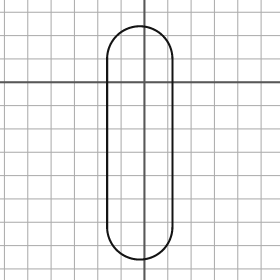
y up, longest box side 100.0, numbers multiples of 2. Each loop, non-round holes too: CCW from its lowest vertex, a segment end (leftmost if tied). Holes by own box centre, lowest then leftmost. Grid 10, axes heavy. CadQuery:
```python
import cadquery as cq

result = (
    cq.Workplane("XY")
    .moveTo(-16.0, -62.0)
    .threePointArc((-2.0, -76.0), (12.0, -62.0))
    .lineTo(12.0, 10.0)
    .threePointArc((-2.0, 24.0), (-16.0, 10.0))
    .close()
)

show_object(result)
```